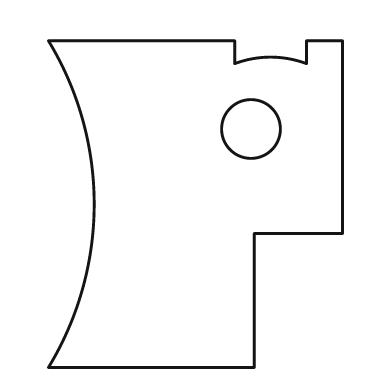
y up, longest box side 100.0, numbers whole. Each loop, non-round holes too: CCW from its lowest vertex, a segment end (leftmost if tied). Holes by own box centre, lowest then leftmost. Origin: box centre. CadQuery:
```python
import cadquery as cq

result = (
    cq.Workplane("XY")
    .moveTo(-45.0, -50.0)
    .lineTo(18.0, -50.0)
    .lineTo(18.0, -9.0)
    .lineTo(45.0, -9.0)
    .lineTo(45.0, 50.0)
    .lineTo(34.0, 50.0)
    .lineTo(34.0, 43.0)
    .threePointArc((23.0, 45.0), (12.0, 43.0))
    .lineTo(12.0, 50.0)
    .lineTo(-45.0, 50.0)
    .threePointArc((-31.0, 0.0), (-45.0, -50.0))
    .close()
    .moveTo(17.0, 23.0)
    .circle(9.0)
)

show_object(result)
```